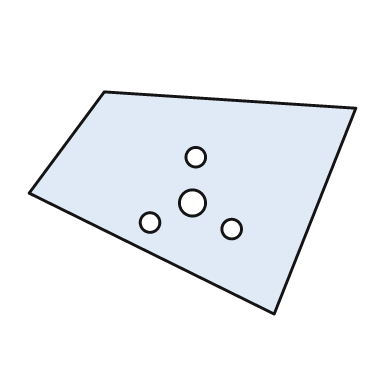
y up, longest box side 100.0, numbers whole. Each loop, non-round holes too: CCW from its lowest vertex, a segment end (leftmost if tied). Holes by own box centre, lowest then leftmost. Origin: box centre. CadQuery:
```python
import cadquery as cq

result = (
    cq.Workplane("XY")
    .moveTo(25.0, -34.0)
    .lineTo(50.0, 29.0)
    .lineTo(-27.0, 34.0)
    .lineTo(-50.0, 3.0)
    .close()
    .moveTo(12.0, -8.0)
    .circle(3.0)
    .moveTo(-13.0, -6.0)
    .circle(3.0)
    .moveTo(0.0, 0.0)
    .circle(4.0)
    .moveTo(1.0, 14.0)
    .circle(3.0)
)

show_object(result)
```